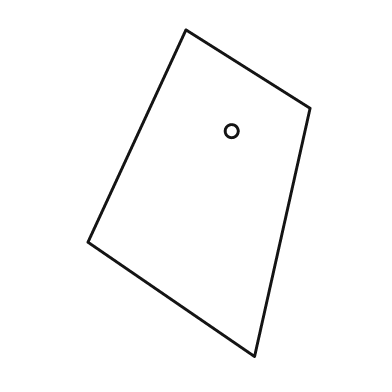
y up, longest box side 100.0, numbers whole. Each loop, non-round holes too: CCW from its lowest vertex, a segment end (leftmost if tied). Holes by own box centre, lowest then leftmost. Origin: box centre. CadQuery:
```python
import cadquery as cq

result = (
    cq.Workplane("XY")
    .moveTo(17.0, -50.0)
    .lineTo(34.0, 26.0)
    .lineTo(-4.0, 50.0)
    .lineTo(-34.0, -15.0)
    .close()
    .moveTo(10.0, 19.0)
    .circle(2.0)
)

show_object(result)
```